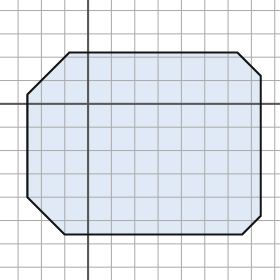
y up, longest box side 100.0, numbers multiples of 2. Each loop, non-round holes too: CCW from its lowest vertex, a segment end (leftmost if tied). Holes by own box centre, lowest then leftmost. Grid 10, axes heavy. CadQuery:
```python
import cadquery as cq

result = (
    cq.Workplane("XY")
    .moveTo(-10.0, -56.0)
    .lineTo(66.0, -56.0)
    .lineTo(74.0, -48.0)
    .lineTo(74.0, 12.0)
    .lineTo(64.0, 22.0)
    .lineTo(-8.0, 22.0)
    .lineTo(-26.0, 4.0)
    .lineTo(-26.0, -40.0)
    .close()
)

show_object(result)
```